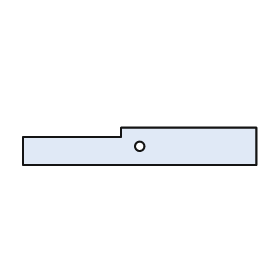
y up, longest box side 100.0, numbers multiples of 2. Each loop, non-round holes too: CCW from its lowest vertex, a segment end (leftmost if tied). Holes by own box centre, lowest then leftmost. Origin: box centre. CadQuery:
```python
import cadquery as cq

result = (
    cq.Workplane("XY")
    .moveTo(-50.0, -8.0)
    .lineTo(50.0, -8.0)
    .lineTo(50.0, 8.0)
    .lineTo(-8.0, 8.0)
    .lineTo(-8.0, 4.0)
    .lineTo(-50.0, 4.0)
    .close()
    .moveTo(0.0, 0.0)
    .circle(2.0)
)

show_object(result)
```